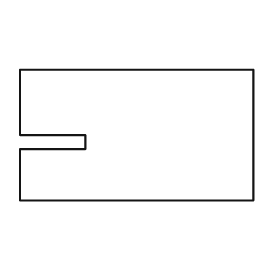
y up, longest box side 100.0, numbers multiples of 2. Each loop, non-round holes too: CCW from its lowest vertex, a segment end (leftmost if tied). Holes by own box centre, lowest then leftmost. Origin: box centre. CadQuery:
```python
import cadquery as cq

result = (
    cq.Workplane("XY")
    .moveTo(-50.0, -28.0)
    .lineTo(50.0, -28.0)
    .lineTo(50.0, 28.0)
    .lineTo(-50.0, 28.0)
    .lineTo(-50.0, 0.0)
    .lineTo(-22.0, 0.0)
    .lineTo(-22.0, -6.0)
    .lineTo(-50.0, -6.0)
    .close()
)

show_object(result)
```